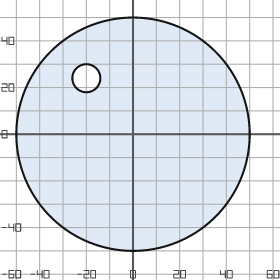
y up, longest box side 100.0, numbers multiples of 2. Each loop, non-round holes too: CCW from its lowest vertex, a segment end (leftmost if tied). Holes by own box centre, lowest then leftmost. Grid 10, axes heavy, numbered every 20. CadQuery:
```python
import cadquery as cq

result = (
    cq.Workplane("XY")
    .moveTo(0.0, 0.0)
    .circle(50.0)
    .moveTo(-20.0, 24.0)
    .circle(6.0)
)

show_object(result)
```